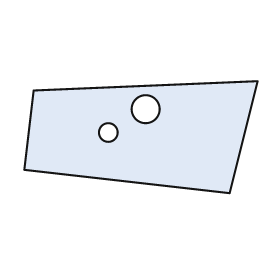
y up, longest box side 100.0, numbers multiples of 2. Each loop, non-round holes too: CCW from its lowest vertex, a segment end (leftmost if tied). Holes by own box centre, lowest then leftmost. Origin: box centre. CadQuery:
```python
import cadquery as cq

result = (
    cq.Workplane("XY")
    .moveTo(38.0, -24.0)
    .lineTo(50.0, 24.0)
    .lineTo(-46.0, 20.0)
    .lineTo(-50.0, -14.0)
    .close()
    .moveTo(-14.0, 2.0)
    .circle(4.0)
    .moveTo(2.0, 12.0)
    .circle(6.0)
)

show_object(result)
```